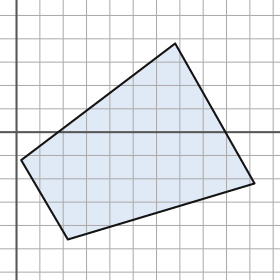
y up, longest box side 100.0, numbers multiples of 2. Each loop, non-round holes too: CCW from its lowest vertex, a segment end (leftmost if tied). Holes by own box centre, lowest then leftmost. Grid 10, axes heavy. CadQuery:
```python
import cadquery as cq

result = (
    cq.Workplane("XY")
    .moveTo(22.0, -46.0)
    .lineTo(102.0, -22.0)
    .lineTo(68.0, 38.0)
    .lineTo(2.0, -12.0)
    .close()
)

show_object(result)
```